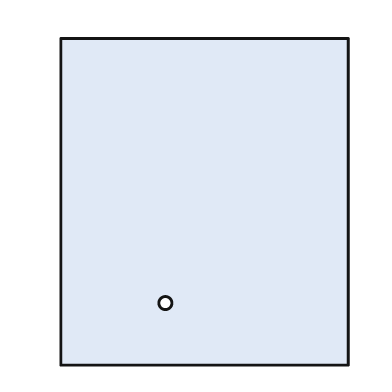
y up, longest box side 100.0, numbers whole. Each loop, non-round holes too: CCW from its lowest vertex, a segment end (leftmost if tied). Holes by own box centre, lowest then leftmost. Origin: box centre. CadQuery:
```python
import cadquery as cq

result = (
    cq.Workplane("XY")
    .moveTo(-44.0, -50.0)
    .lineTo(44.0, -50.0)
    .lineTo(44.0, 50.0)
    .lineTo(-44.0, 50.0)
    .close()
    .moveTo(-12.0, -31.0)
    .circle(2.0)
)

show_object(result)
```